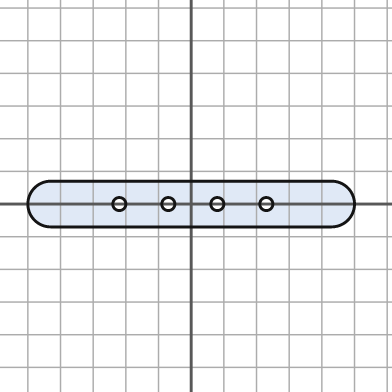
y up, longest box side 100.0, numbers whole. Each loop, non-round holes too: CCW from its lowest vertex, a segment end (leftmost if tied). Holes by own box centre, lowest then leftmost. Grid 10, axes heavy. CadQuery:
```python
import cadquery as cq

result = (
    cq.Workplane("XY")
    .moveTo(-43.0, -7.0)
    .lineTo(43.0, -7.0)
    .threePointArc((50.0, 0.0), (43.0, 7.0))
    .lineTo(-43.0, 7.0)
    .threePointArc((-50.0, 0.0), (-43.0, -7.0))
    .close()
    .moveTo(-22.0, 0.0)
    .circle(2.0)
    .moveTo(-7.0, 0.0)
    .circle(2.0)
    .moveTo(8.0, 0.0)
    .circle(2.0)
    .moveTo(23.0, 0.0)
    .circle(2.0)
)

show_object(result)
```